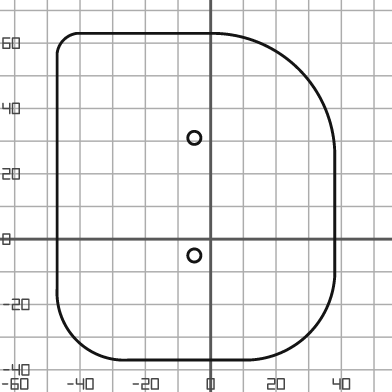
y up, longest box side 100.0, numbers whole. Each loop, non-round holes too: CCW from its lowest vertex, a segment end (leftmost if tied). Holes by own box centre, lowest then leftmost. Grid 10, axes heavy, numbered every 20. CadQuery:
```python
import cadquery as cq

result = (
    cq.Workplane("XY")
    .moveTo(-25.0, -37.0)
    .lineTo(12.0, -37.0)
    .threePointArc((30.0, -29.0), (38.0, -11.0))
    .lineTo(38.0, 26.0)
    .threePointArc((27.0, 52.0), (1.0, 63.0))
    .lineTo(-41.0, 63.0)
    .threePointArc((-45.0, 61.0), (-47.0, 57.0))
    .lineTo(-47.0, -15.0)
    .threePointArc((-41.0, -31.0), (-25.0, -37.0))
    .close()
    .moveTo(-5.0, -5.0)
    .circle(2.0)
    .moveTo(-5.0, 31.0)
    .circle(2.0)
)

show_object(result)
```